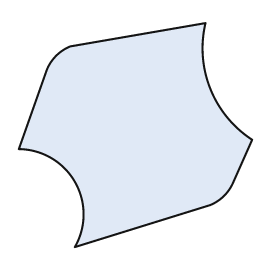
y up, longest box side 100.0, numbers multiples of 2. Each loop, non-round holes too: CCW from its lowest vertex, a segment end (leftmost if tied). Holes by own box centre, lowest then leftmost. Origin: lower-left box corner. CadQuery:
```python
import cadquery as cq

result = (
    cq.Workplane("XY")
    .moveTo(24.0, 0.0)
    .lineTo(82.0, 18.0)
    .threePointArc((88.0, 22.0), (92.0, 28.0))
    .lineTo(100.0, 46.0)
    .threePointArc((82.0, 68.0), (80.0, 96.0))
    .lineTo(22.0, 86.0)
    .threePointArc((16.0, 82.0), (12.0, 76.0))
    .lineTo(0.0, 42.0)
    .threePointArc((24.0, 28.0), (24.0, 0.0))
    .close()
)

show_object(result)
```